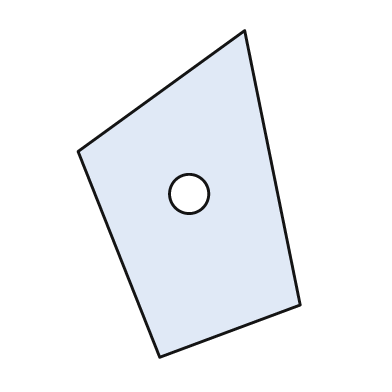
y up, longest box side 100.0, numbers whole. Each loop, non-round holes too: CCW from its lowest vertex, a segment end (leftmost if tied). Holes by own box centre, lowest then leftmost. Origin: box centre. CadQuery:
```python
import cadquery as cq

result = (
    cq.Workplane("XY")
    .moveTo(-9.0, -50.0)
    .lineTo(34.0, -34.0)
    .lineTo(17.0, 50.0)
    .lineTo(-34.0, 13.0)
    .close()
    .moveTo(0.0, 0.0)
    .circle(6.0)
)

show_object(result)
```